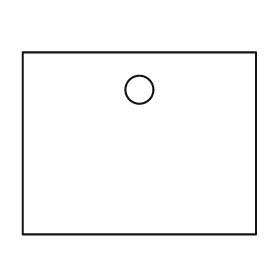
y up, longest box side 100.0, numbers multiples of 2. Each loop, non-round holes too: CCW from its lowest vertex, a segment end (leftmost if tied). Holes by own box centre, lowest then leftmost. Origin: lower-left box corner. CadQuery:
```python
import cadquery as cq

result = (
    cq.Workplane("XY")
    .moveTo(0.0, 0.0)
    .lineTo(100.0, 0.0)
    .lineTo(100.0, 78.0)
    .lineTo(0.0, 78.0)
    .close()
    .moveTo(50.0, 62.0)
    .circle(6.0)
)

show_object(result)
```